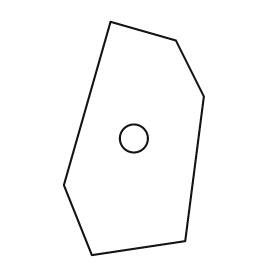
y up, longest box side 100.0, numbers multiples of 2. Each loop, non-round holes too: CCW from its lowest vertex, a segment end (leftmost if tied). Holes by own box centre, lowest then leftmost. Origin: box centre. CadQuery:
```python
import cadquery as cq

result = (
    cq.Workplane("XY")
    .moveTo(-18.0, -50.0)
    .lineTo(22.0, -44.0)
    .lineTo(30.0, 18.0)
    .lineTo(18.0, 42.0)
    .lineTo(-10.0, 50.0)
    .lineTo(-30.0, -20.0)
    .close()
    .moveTo(0.0, 0.0)
    .circle(6.0)
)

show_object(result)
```